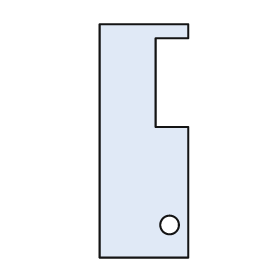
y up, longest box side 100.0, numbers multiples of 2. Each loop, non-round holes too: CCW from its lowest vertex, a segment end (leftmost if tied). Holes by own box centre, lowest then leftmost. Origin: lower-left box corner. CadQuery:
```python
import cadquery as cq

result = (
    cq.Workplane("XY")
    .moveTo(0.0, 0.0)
    .lineTo(38.0, 0.0)
    .lineTo(38.0, 56.0)
    .lineTo(24.0, 56.0)
    .lineTo(24.0, 94.0)
    .lineTo(38.0, 94.0)
    .lineTo(38.0, 100.0)
    .lineTo(0.0, 100.0)
    .close()
    .moveTo(30.0, 14.0)
    .circle(4.0)
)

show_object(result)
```